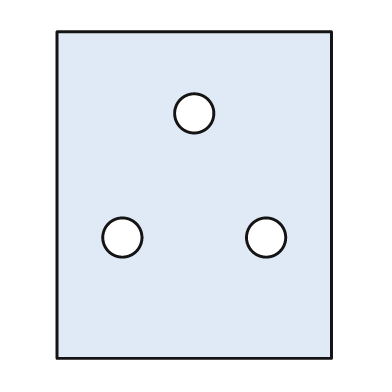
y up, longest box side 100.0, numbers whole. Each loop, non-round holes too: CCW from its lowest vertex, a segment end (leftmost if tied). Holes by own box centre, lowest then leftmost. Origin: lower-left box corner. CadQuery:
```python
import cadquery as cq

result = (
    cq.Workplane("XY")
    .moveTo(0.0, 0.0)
    .lineTo(84.0, 0.0)
    .lineTo(84.0, 100.0)
    .lineTo(0.0, 100.0)
    .close()
    .moveTo(20.0, 37.0)
    .circle(6.0)
    .moveTo(64.0, 37.0)
    .circle(6.0)
    .moveTo(42.0, 75.0)
    .circle(6.0)
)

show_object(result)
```